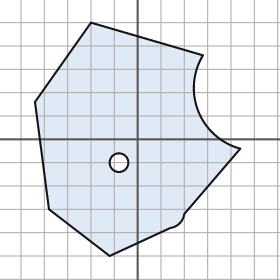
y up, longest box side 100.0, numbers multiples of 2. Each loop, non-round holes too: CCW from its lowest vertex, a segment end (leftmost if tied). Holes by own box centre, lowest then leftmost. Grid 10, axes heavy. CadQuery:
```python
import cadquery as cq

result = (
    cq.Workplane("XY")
    .moveTo(-12.0, -50.0)
    .lineTo(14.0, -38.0)
    .threePointArc((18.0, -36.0), (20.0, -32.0))
    .lineTo(44.0, -4.0)
    .threePointArc((26.0, 12.0), (28.0, 36.0))
    .lineTo(-20.0, 50.0)
    .lineTo(-44.0, 16.0)
    .lineTo(-38.0, -30.0)
    .close()
    .moveTo(-8.0, -10.0)
    .circle(4.0)
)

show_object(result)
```